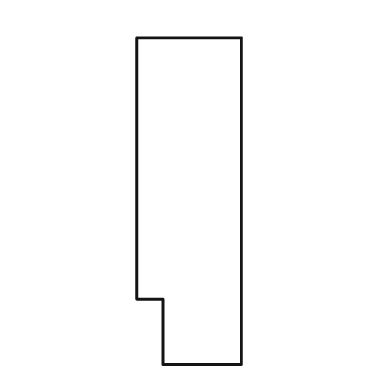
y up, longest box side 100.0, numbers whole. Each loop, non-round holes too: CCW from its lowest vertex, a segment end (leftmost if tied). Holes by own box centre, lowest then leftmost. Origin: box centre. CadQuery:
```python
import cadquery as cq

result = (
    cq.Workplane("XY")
    .moveTo(-8.0, -50.0)
    .lineTo(16.0, -50.0)
    .lineTo(16.0, 50.0)
    .lineTo(-16.0, 50.0)
    .lineTo(-16.0, -30.0)
    .lineTo(-8.0, -30.0)
    .close()
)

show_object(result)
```